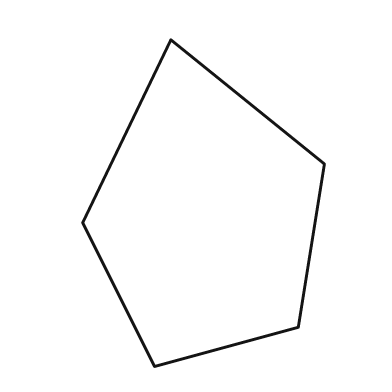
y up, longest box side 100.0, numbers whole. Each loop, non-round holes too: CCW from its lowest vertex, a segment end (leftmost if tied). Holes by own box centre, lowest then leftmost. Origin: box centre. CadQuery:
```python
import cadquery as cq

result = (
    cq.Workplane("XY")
    .moveTo(-15.0, -50.0)
    .lineTo(29.0, -38.0)
    .lineTo(37.0, 12.0)
    .lineTo(-10.0, 50.0)
    .lineTo(-37.0, -6.0)
    .close()
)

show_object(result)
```